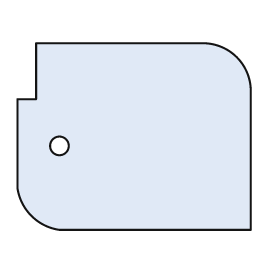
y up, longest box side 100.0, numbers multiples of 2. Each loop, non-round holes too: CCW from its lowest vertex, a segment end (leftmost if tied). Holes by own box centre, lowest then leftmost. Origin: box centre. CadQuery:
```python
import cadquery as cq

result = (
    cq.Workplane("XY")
    .moveTo(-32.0, -40.0)
    .lineTo(50.0, -40.0)
    .lineTo(50.0, 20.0)
    .threePointArc((44.0, 34.0), (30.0, 40.0))
    .lineTo(-42.0, 40.0)
    .lineTo(-42.0, 16.0)
    .lineTo(-50.0, 16.0)
    .lineTo(-50.0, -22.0)
    .threePointArc((-44.0, -34.0), (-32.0, -40.0))
    .close()
    .moveTo(-32.0, -4.0)
    .circle(4.0)
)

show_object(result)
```